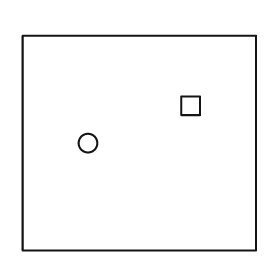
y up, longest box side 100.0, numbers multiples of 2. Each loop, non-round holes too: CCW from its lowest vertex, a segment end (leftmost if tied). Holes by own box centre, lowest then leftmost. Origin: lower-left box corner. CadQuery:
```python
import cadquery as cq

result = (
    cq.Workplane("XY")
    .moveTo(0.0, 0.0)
    .lineTo(100.0, 0.0)
    .lineTo(100.0, 92.0)
    .lineTo(0.0, 92.0)
    .close()
    .moveTo(28.0, 46.0)
    .circle(4.0)
    .moveTo(68.0, 58.0)
    .lineTo(76.0, 58.0)
    .lineTo(76.0, 66.0)
    .lineTo(68.0, 66.0)
    .close()
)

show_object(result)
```